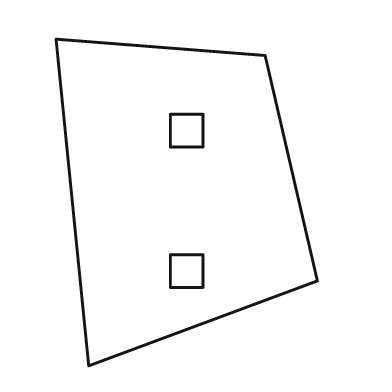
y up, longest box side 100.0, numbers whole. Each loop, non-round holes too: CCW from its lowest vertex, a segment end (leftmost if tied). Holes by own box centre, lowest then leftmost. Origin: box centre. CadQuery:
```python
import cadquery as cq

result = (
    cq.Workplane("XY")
    .moveTo(-30.0, -50.0)
    .lineTo(40.0, -24.0)
    .lineTo(24.0, 45.0)
    .lineTo(-40.0, 50.0)
    .close()
    .moveTo(-5.0, -26.0)
    .lineTo(5.0, -26.0)
    .lineTo(5.0, -16.0)
    .lineTo(-5.0, -16.0)
    .close()
    .moveTo(-5.0, 17.0)
    .lineTo(5.0, 17.0)
    .lineTo(5.0, 27.0)
    .lineTo(-5.0, 27.0)
    .close()
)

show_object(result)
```